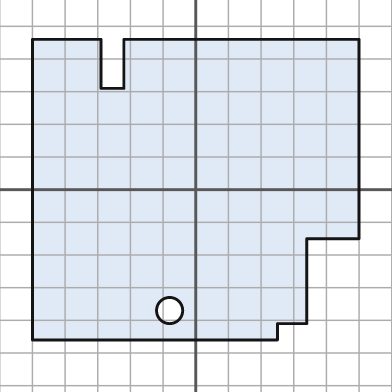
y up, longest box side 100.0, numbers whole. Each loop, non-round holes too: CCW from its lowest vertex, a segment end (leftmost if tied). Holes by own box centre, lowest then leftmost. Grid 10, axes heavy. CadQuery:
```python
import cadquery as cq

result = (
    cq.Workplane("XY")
    .moveTo(-50.0, -46.0)
    .lineTo(25.0, -46.0)
    .lineTo(25.0, -41.0)
    .lineTo(34.0, -41.0)
    .lineTo(34.0, -15.0)
    .lineTo(50.0, -15.0)
    .lineTo(50.0, 46.0)
    .lineTo(-22.0, 46.0)
    .lineTo(-22.0, 31.0)
    .lineTo(-29.0, 31.0)
    .lineTo(-29.0, 46.0)
    .lineTo(-50.0, 46.0)
    .close()
    .moveTo(-8.0, -37.0)
    .circle(4.0)
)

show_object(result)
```